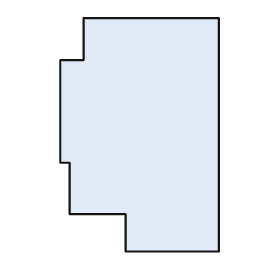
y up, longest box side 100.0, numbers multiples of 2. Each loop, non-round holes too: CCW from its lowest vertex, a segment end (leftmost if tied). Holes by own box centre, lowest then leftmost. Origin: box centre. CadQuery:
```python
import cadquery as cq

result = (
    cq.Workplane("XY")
    .moveTo(-6.0, -50.0)
    .lineTo(34.0, -50.0)
    .lineTo(34.0, 50.0)
    .lineTo(-24.0, 50.0)
    .lineTo(-24.0, 32.0)
    .lineTo(-34.0, 32.0)
    .lineTo(-34.0, -12.0)
    .lineTo(-30.0, -12.0)
    .lineTo(-30.0, -34.0)
    .lineTo(-6.0, -34.0)
    .close()
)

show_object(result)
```